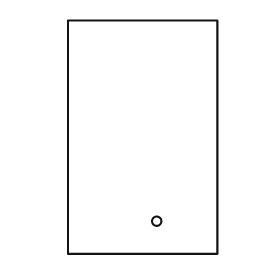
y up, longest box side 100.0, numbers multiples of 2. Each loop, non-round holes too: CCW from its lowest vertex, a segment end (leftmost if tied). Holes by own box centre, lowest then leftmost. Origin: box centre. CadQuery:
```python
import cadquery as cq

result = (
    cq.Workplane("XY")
    .moveTo(-32.0, -50.0)
    .lineTo(32.0, -50.0)
    .lineTo(32.0, 50.0)
    .lineTo(-32.0, 50.0)
    .close()
    .moveTo(6.0, -36.0)
    .circle(2.0)
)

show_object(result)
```